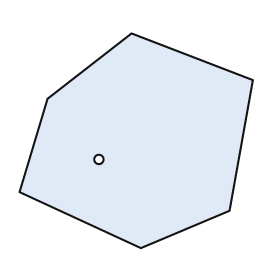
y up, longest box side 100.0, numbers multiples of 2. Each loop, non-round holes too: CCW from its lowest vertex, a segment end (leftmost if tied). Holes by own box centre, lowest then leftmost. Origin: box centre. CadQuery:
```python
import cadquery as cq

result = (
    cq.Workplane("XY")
    .moveTo(2.0, -46.0)
    .lineTo(40.0, -30.0)
    .lineTo(50.0, 26.0)
    .lineTo(-2.0, 46.0)
    .lineTo(-38.0, 18.0)
    .lineTo(-50.0, -22.0)
    .close()
    .moveTo(-16.0, -8.0)
    .circle(2.0)
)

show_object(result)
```